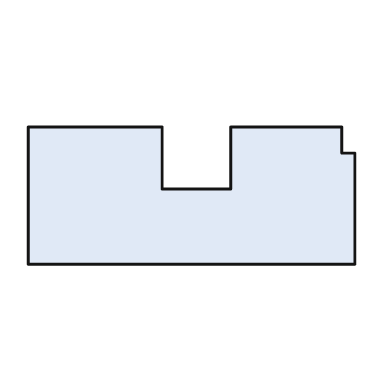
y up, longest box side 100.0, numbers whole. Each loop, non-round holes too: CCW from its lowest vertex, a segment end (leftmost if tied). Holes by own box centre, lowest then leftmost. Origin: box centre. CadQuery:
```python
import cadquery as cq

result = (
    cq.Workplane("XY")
    .moveTo(-50.0, -21.0)
    .lineTo(50.0, -21.0)
    .lineTo(50.0, 13.0)
    .lineTo(46.0, 13.0)
    .lineTo(46.0, 21.0)
    .lineTo(12.0, 21.0)
    .lineTo(12.0, 2.0)
    .lineTo(-9.0, 2.0)
    .lineTo(-9.0, 21.0)
    .lineTo(-50.0, 21.0)
    .close()
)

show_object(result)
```